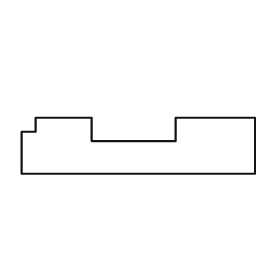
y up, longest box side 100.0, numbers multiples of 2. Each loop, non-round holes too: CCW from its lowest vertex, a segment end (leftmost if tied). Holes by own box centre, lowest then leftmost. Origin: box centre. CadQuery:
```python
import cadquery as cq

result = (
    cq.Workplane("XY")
    .moveTo(-50.0, -12.0)
    .lineTo(50.0, -12.0)
    .lineTo(50.0, 12.0)
    .lineTo(16.0, 12.0)
    .lineTo(16.0, 2.0)
    .lineTo(-20.0, 2.0)
    .lineTo(-20.0, 12.0)
    .lineTo(-44.0, 12.0)
    .lineTo(-44.0, 6.0)
    .lineTo(-50.0, 6.0)
    .close()
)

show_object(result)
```